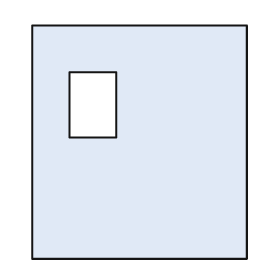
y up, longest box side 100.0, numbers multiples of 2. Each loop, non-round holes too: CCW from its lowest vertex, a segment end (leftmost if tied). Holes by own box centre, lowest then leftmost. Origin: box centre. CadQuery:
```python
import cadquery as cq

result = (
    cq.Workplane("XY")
    .moveTo(-46.0, -50.0)
    .lineTo(46.0, -50.0)
    .lineTo(46.0, 50.0)
    .lineTo(-46.0, 50.0)
    .close()
    .moveTo(-30.0, 2.0)
    .lineTo(-10.0, 2.0)
    .lineTo(-10.0, 30.0)
    .lineTo(-30.0, 30.0)
    .close()
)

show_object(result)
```